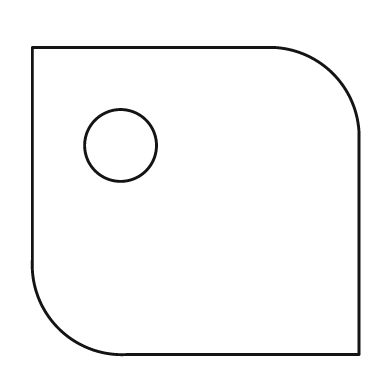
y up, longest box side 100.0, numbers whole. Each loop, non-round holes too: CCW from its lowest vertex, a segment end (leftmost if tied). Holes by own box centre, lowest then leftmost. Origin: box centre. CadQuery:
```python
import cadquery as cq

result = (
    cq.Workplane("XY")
    .moveTo(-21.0, -47.0)
    .lineTo(50.0, -47.0)
    .lineTo(50.0, 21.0)
    .threePointArc((42.0, 39.0), (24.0, 47.0))
    .lineTo(-50.0, 47.0)
    .lineTo(-50.0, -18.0)
    .threePointArc((-42.0, -39.0), (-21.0, -47.0))
    .close()
    .moveTo(-23.0, 17.0)
    .circle(11.0)
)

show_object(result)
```